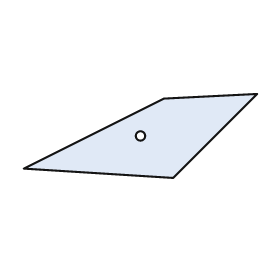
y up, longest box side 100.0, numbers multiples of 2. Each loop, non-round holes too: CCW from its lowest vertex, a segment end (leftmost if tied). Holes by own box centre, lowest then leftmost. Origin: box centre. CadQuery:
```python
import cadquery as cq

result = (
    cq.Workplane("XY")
    .moveTo(14.0, -18.0)
    .lineTo(50.0, 18.0)
    .lineTo(10.0, 16.0)
    .lineTo(-50.0, -14.0)
    .close()
    .moveTo(0.0, 0.0)
    .circle(2.0)
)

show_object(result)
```